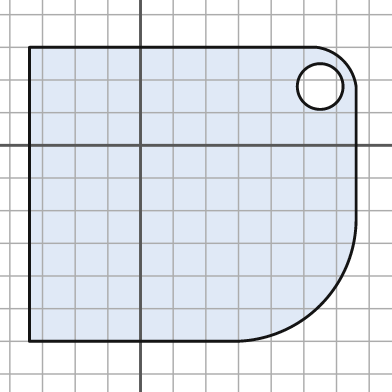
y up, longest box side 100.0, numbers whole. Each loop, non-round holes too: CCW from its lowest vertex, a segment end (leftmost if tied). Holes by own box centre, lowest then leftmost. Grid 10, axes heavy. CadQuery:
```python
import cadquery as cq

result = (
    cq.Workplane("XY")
    .moveTo(-34.0, -60.0)
    .lineTo(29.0, -60.0)
    .threePointArc((55.0, -49.0), (66.0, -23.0))
    .lineTo(66.0, 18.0)
    .threePointArc((62.0, 26.0), (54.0, 30.0))
    .lineTo(-34.0, 30.0)
    .close()
    .moveTo(55.0, 18.0)
    .circle(7.0)
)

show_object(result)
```